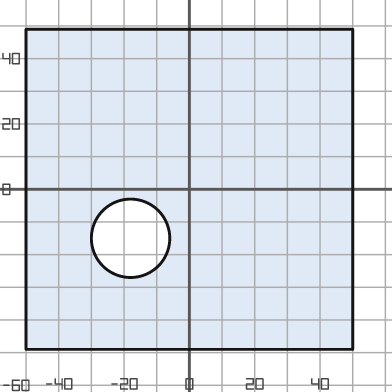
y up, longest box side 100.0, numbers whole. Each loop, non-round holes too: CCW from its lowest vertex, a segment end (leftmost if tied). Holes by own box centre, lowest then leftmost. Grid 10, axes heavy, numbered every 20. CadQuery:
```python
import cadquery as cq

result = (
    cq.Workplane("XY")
    .moveTo(-50.0, -49.0)
    .lineTo(50.0, -49.0)
    .lineTo(50.0, 49.0)
    .lineTo(-50.0, 49.0)
    .close()
    .moveTo(-18.0, -15.0)
    .circle(12.0)
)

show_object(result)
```